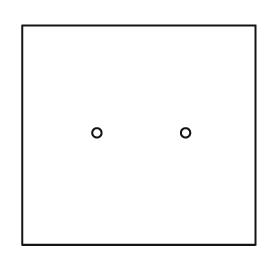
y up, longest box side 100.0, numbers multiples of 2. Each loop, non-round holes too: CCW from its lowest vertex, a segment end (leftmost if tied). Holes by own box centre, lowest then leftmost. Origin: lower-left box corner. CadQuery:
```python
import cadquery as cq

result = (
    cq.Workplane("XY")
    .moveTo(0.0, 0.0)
    .lineTo(100.0, 0.0)
    .lineTo(100.0, 94.0)
    .lineTo(0.0, 94.0)
    .close()
    .moveTo(32.0, 48.0)
    .circle(2.0)
    .moveTo(70.0, 48.0)
    .circle(2.0)
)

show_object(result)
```